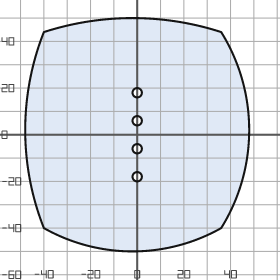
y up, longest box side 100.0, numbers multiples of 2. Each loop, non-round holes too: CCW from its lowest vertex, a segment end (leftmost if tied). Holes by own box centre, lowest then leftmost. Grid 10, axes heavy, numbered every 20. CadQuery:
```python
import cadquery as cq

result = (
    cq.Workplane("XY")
    .moveTo(-40.0, -40.0)
    .threePointArc((-2.0, -50.0), (36.0, -40.0))
    .threePointArc((48.0, 2.0), (36.0, 44.0))
    .threePointArc((-2.0, 50.0), (-40.0, 44.0))
    .threePointArc((-48.0, 2.0), (-40.0, -40.0))
    .close()
    .moveTo(0.0, -18.0)
    .circle(2.0)
    .moveTo(0.0, -6.0)
    .circle(2.0)
    .moveTo(0.0, 6.0)
    .circle(2.0)
    .moveTo(0.0, 18.0)
    .circle(2.0)
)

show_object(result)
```